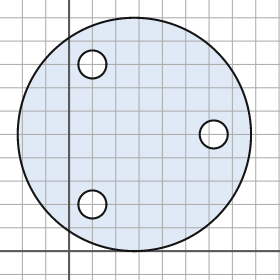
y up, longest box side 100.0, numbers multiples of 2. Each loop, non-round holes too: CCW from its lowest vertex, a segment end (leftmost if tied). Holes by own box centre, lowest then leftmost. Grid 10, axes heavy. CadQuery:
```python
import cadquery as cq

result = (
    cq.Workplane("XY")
    .moveTo(28.0, 50.0)
    .circle(50.0)
    .moveTo(10.0, 20.0)
    .circle(6.0)
    .moveTo(62.0, 50.0)
    .circle(6.0)
    .moveTo(10.0, 80.0)
    .circle(6.0)
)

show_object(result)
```